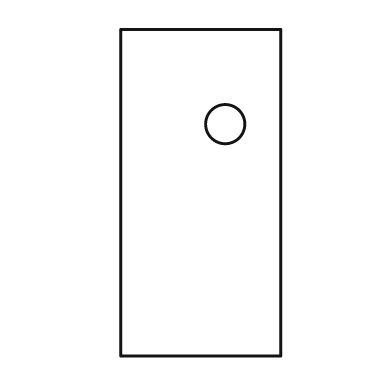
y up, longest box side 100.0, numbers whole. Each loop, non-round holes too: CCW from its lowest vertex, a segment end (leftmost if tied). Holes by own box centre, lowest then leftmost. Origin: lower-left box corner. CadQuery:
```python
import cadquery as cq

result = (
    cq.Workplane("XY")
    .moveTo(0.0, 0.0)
    .lineTo(49.0, 0.0)
    .lineTo(49.0, 100.0)
    .lineTo(0.0, 100.0)
    .close()
    .moveTo(32.0, 71.0)
    .circle(6.0)
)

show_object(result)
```